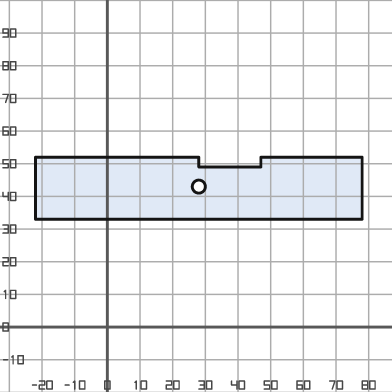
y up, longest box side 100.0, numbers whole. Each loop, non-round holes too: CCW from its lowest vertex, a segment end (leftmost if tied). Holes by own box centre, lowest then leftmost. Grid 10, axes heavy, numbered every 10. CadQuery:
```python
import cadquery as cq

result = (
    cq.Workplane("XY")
    .moveTo(-22.0, 33.0)
    .lineTo(78.0, 33.0)
    .lineTo(78.0, 52.0)
    .lineTo(47.0, 52.0)
    .lineTo(47.0, 49.0)
    .lineTo(28.0, 49.0)
    .lineTo(28.0, 52.0)
    .lineTo(-22.0, 52.0)
    .close()
    .moveTo(28.0, 43.0)
    .circle(2.0)
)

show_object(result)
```